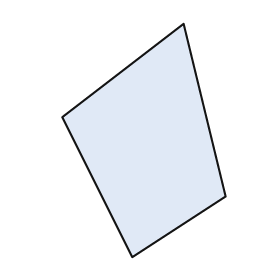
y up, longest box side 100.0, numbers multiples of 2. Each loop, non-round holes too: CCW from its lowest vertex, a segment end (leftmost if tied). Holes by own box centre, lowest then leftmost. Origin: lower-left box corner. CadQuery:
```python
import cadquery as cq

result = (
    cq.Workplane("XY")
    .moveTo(30.0, 0.0)
    .lineTo(70.0, 26.0)
    .lineTo(52.0, 100.0)
    .lineTo(0.0, 60.0)
    .close()
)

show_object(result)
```